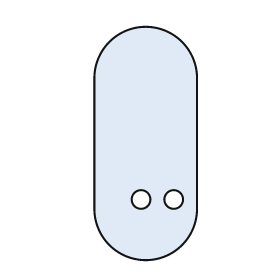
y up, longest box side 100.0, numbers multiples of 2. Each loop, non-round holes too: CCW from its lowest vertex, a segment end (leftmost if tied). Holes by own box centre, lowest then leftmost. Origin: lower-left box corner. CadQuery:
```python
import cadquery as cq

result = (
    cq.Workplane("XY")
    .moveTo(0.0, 22.0)
    .threePointArc((22.0, 0.0), (44.0, 22.0))
    .lineTo(44.0, 78.0)
    .threePointArc((22.0, 100.0), (0.0, 78.0))
    .close()
    .moveTo(20.0, 26.0)
    .circle(4.0)
    .moveTo(34.0, 26.0)
    .circle(4.0)
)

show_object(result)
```